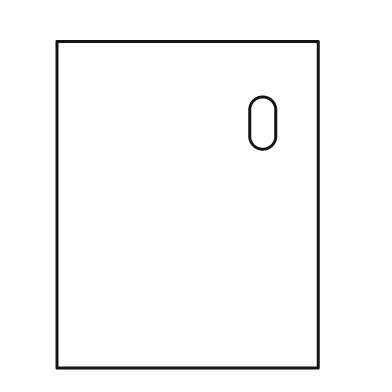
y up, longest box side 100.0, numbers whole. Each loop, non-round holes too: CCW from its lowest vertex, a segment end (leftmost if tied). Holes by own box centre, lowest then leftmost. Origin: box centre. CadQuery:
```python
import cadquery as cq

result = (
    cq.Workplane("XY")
    .moveTo(-40.0, -50.0)
    .lineTo(40.0, -50.0)
    .lineTo(40.0, 50.0)
    .lineTo(-40.0, 50.0)
    .close()
    .moveTo(19.0, 21.0)
    .threePointArc((23.0, 17.0), (27.0, 21.0))
    .lineTo(27.0, 29.0)
    .threePointArc((23.0, 33.0), (19.0, 29.0))
    .close()
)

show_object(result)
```